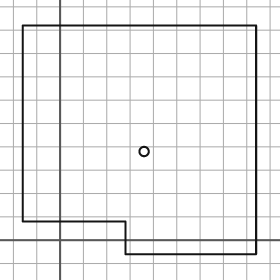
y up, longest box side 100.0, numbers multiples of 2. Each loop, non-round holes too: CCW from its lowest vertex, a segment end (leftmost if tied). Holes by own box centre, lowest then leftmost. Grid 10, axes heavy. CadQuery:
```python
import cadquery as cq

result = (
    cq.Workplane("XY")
    .moveTo(28.0, -6.0)
    .lineTo(84.0, -6.0)
    .lineTo(84.0, 92.0)
    .lineTo(-16.0, 92.0)
    .lineTo(-16.0, 8.0)
    .lineTo(28.0, 8.0)
    .close()
    .moveTo(36.0, 38.0)
    .circle(2.0)
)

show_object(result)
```